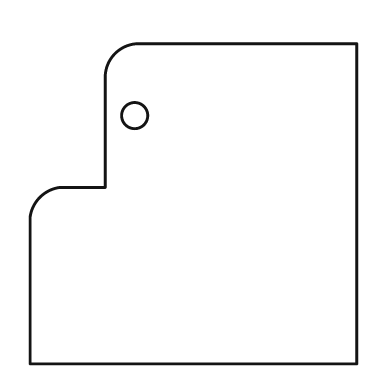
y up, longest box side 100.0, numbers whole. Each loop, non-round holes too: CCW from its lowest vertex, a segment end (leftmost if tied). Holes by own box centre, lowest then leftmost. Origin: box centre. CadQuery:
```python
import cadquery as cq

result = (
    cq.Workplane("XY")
    .moveTo(-50.0, -49.0)
    .lineTo(50.0, -49.0)
    .lineTo(50.0, 49.0)
    .lineTo(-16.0, 49.0)
    .threePointArc((-24.0, 46.0), (-27.0, 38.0))
    .lineTo(-27.0, 5.0)
    .lineTo(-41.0, 5.0)
    .threePointArc((-47.0, 2.0), (-50.0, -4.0))
    .close()
    .moveTo(-18.0, 27.0)
    .circle(4.0)
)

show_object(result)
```